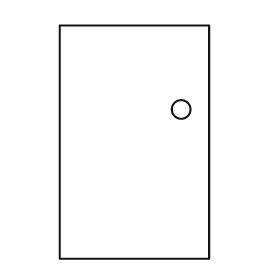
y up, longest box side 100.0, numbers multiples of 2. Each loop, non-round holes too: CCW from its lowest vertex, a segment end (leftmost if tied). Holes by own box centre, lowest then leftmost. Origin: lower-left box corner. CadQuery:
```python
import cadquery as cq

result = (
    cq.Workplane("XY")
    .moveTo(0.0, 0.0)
    .lineTo(64.0, 0.0)
    .lineTo(64.0, 100.0)
    .lineTo(0.0, 100.0)
    .close()
    .moveTo(52.0, 64.0)
    .circle(4.0)
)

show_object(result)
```